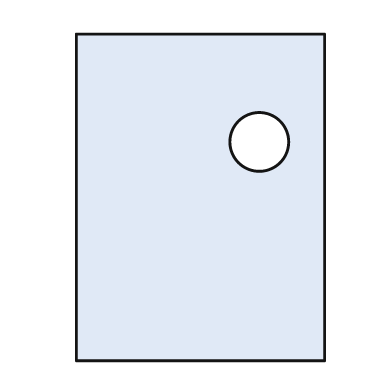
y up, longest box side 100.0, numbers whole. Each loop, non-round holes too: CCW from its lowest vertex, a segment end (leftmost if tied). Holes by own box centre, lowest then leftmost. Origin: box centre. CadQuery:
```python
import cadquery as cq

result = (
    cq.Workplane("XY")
    .moveTo(-38.0, -50.0)
    .lineTo(38.0, -50.0)
    .lineTo(38.0, 50.0)
    .lineTo(-38.0, 50.0)
    .close()
    .moveTo(18.0, 17.0)
    .circle(9.0)
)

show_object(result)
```